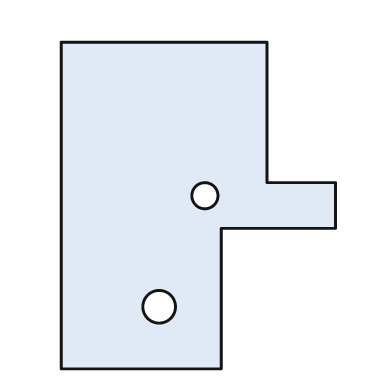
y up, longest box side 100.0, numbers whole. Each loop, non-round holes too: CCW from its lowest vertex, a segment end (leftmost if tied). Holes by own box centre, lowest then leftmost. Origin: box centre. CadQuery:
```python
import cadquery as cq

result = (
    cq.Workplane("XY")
    .moveTo(-42.0, -50.0)
    .lineTo(7.0, -50.0)
    .lineTo(7.0, -7.0)
    .lineTo(42.0, -7.0)
    .lineTo(42.0, 7.0)
    .lineTo(21.0, 7.0)
    .lineTo(21.0, 50.0)
    .lineTo(-42.0, 50.0)
    .close()
    .moveTo(-12.0, -31.0)
    .circle(5.0)
    .moveTo(2.0, 3.0)
    .circle(4.0)
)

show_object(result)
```